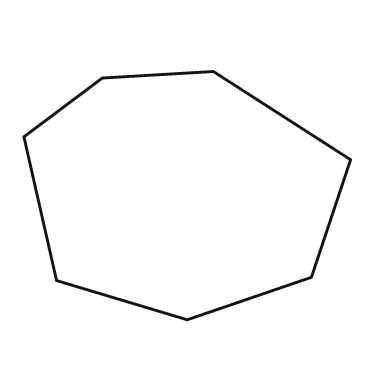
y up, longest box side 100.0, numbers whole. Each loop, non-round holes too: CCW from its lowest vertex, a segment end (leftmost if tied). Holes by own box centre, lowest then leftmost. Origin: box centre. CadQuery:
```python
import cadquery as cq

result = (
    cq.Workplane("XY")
    .moveTo(0.0, -38.0)
    .lineTo(38.0, -25.0)
    .lineTo(50.0, 11.0)
    .lineTo(8.0, 38.0)
    .lineTo(-26.0, 36.0)
    .lineTo(-50.0, 18.0)
    .lineTo(-40.0, -26.0)
    .close()
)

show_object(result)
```